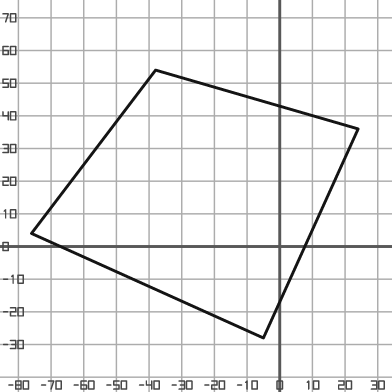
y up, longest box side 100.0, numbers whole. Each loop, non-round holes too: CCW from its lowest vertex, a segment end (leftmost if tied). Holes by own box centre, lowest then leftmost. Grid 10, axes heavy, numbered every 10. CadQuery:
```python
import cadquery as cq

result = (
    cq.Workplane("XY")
    .moveTo(-5.0, -28.0)
    .lineTo(24.0, 36.0)
    .lineTo(-38.0, 54.0)
    .lineTo(-76.0, 4.0)
    .close()
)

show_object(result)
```